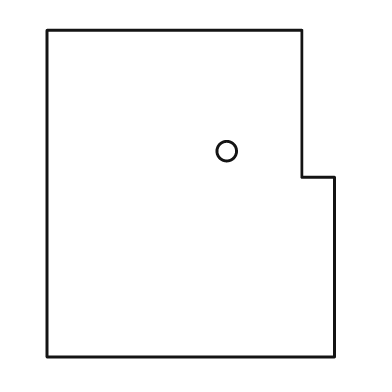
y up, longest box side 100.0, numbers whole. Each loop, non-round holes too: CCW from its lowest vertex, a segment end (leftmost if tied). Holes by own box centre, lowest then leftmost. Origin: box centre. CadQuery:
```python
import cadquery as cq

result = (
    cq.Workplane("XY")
    .moveTo(-44.0, -50.0)
    .lineTo(44.0, -50.0)
    .lineTo(44.0, 5.0)
    .lineTo(34.0, 5.0)
    .lineTo(34.0, 50.0)
    .lineTo(-44.0, 50.0)
    .close()
    .moveTo(11.0, 13.0)
    .circle(3.0)
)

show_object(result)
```